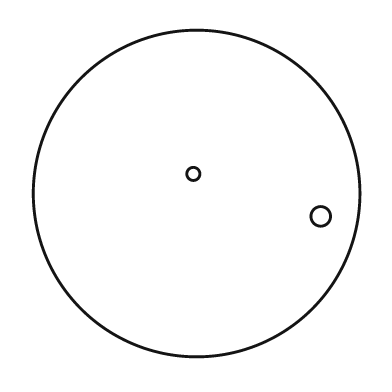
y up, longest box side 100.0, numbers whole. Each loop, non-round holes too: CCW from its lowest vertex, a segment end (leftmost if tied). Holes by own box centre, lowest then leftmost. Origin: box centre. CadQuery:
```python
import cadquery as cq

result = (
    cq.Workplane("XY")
    .moveTo(0.0, 0.0)
    .circle(50.0)
    .moveTo(38.0, -7.0)
    .circle(3.0)
    .moveTo(-1.0, 6.0)
    .circle(2.0)
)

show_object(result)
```